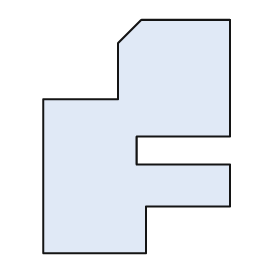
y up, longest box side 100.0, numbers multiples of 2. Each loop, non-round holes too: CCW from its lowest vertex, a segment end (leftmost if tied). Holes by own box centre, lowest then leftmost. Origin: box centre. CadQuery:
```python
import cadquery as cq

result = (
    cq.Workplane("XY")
    .moveTo(-40.0, -50.0)
    .lineTo(4.0, -50.0)
    .lineTo(4.0, -30.0)
    .lineTo(40.0, -30.0)
    .lineTo(40.0, -12.0)
    .lineTo(0.0, -12.0)
    .lineTo(0.0, 0.0)
    .lineTo(40.0, 0.0)
    .lineTo(40.0, 50.0)
    .lineTo(2.0, 50.0)
    .lineTo(-8.0, 40.0)
    .lineTo(-8.0, 16.0)
    .lineTo(-40.0, 16.0)
    .close()
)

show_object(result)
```